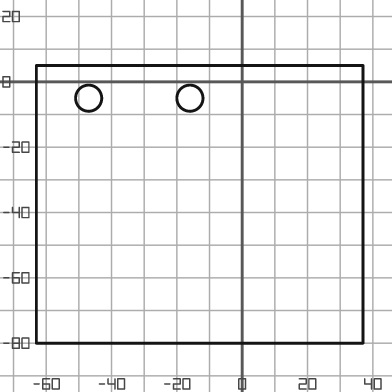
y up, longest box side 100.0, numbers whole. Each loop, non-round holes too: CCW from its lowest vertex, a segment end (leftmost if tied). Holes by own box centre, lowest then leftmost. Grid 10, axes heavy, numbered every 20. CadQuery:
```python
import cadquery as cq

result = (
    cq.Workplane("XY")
    .moveTo(-63.0, -80.0)
    .lineTo(37.0, -80.0)
    .lineTo(37.0, 5.0)
    .lineTo(-63.0, 5.0)
    .close()
    .moveTo(-47.0, -5.0)
    .circle(4.0)
    .moveTo(-16.0, -5.0)
    .circle(4.0)
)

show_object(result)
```